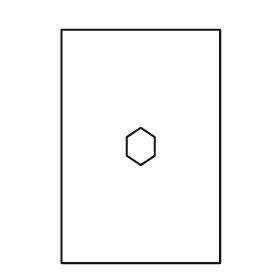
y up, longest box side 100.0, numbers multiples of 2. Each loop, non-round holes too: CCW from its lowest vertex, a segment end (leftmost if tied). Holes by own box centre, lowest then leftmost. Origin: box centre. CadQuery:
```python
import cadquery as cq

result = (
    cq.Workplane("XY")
    .moveTo(-34.0, -50.0)
    .lineTo(34.0, -50.0)
    .lineTo(34.0, 50.0)
    .lineTo(-34.0, 50.0)
    .close()
    .moveTo(0.0, -8.0)
    .lineTo(6.0, -4.0)
    .lineTo(6.0, 4.0)
    .lineTo(0.0, 8.0)
    .lineTo(-6.0, 4.0)
    .lineTo(-6.0, -4.0)
    .close()
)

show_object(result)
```